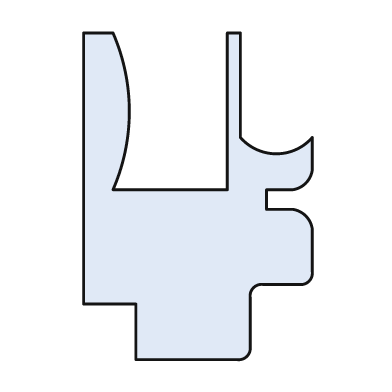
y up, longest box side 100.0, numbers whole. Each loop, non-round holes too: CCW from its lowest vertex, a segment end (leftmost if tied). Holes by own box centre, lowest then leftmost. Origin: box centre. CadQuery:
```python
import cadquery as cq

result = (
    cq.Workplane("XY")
    .moveTo(-19.0, -50.0)
    .lineTo(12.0, -50.0)
    .threePointArc((15.0, -49.0), (16.0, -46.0))
    .lineTo(16.0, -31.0)
    .threePointArc((17.0, -28.0), (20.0, -27.0))
    .lineTo(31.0, -27.0)
    .threePointArc((34.0, -26.0), (35.0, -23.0))
    .lineTo(35.0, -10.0)
    .threePointArc((33.0, -6.0), (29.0, -4.0))
    .lineTo(21.0, -4.0)
    .lineTo(21.0, 2.0)
    .lineTo(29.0, 2.0)
    .threePointArc((33.0, 4.0), (35.0, 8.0))
    .lineTo(35.0, 18.0)
    .threePointArc((24.0, 13.0), (13.0, 18.0))
    .lineTo(13.0, 50.0)
    .lineTo(9.0, 50.0)
    .lineTo(9.0, 2.0)
    .lineTo(-26.0, 2.0)
    .threePointArc((-21.0, 26.0), (-26.0, 50.0))
    .lineTo(-35.0, 50.0)
    .lineTo(-35.0, -33.0)
    .lineTo(-19.0, -33.0)
    .close()
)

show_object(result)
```